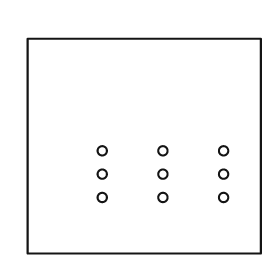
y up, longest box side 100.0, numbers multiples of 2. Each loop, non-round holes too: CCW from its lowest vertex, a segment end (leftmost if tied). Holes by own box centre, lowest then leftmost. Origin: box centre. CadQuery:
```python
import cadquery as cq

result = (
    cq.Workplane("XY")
    .moveTo(-50.0, -46.0)
    .lineTo(50.0, -46.0)
    .lineTo(50.0, 46.0)
    .lineTo(-50.0, 46.0)
    .close()
    .moveTo(-18.0, -22.0)
    .circle(2.0)
    .moveTo(8.0, -22.0)
    .circle(2.0)
    .moveTo(34.0, -22.0)
    .circle(2.0)
    .moveTo(-18.0, -12.0)
    .circle(2.0)
    .moveTo(8.0, -12.0)
    .circle(2.0)
    .moveTo(34.0, -12.0)
    .circle(2.0)
    .moveTo(-18.0, -2.0)
    .circle(2.0)
    .moveTo(8.0, -2.0)
    .circle(2.0)
    .moveTo(34.0, -2.0)
    .circle(2.0)
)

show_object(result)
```